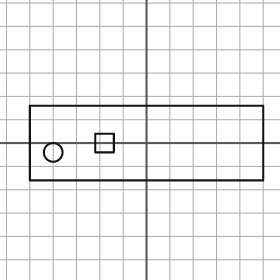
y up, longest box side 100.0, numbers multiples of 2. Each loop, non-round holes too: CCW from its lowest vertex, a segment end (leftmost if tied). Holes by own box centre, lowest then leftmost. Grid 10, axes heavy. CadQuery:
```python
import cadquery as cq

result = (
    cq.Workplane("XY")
    .moveTo(-50.0, -16.0)
    .lineTo(50.0, -16.0)
    .lineTo(50.0, 16.0)
    .lineTo(-50.0, 16.0)
    .close()
    .moveTo(-40.0, -4.0)
    .circle(4.0)
    .moveTo(-22.0, -4.0)
    .lineTo(-14.0, -4.0)
    .lineTo(-14.0, 4.0)
    .lineTo(-22.0, 4.0)
    .close()
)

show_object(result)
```